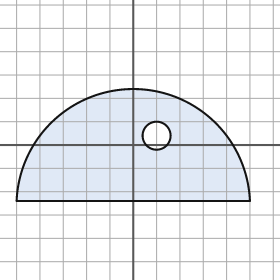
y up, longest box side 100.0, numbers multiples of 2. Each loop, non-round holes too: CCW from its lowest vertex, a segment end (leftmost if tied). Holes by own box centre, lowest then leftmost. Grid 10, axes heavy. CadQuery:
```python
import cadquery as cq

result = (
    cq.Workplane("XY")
    .moveTo(-50.0, -24.0)
    .lineTo(50.0, -24.0)
    .threePointArc((0.0, 24.0), (-50.0, -24.0))
    .close()
    .moveTo(10.0, 4.0)
    .circle(6.0)
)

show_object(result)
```